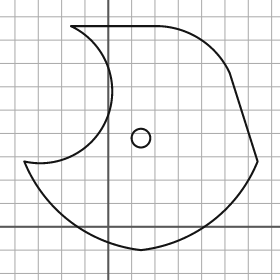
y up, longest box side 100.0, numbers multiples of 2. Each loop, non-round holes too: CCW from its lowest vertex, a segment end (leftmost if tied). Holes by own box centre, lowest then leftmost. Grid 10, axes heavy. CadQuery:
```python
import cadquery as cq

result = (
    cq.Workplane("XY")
    .moveTo(14.0, -10.0)
    .threePointArc((44.0, 2.0), (64.0, 28.0))
    .lineTo(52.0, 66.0)
    .threePointArc((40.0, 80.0), (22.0, 86.0))
    .lineTo(-16.0, 86.0)
    .threePointArc((0.0, 48.0), (-36.0, 28.0))
    .threePointArc((-16.0, 2.0), (14.0, -10.0))
    .close()
    .moveTo(14.0, 38.0)
    .circle(4.0)
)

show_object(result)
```